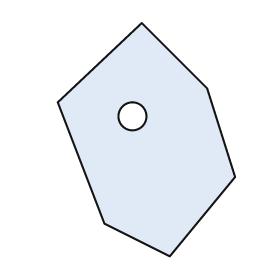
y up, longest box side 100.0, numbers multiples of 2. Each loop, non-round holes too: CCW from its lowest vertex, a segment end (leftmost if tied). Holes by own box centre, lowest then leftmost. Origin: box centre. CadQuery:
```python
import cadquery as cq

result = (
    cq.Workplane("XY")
    .moveTo(10.0, -50.0)
    .lineTo(38.0, -16.0)
    .lineTo(26.0, 22.0)
    .lineTo(-2.0, 50.0)
    .lineTo(-38.0, 16.0)
    .lineTo(-18.0, -36.0)
    .close()
    .moveTo(-6.0, 10.0)
    .circle(6.0)
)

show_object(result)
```